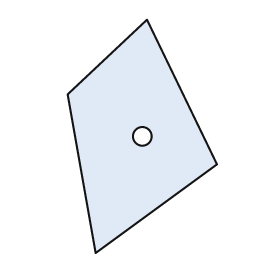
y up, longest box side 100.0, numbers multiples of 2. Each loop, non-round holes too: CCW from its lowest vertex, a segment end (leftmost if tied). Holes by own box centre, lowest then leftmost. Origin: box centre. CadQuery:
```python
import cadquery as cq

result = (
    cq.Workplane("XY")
    .moveTo(-20.0, -50.0)
    .lineTo(32.0, -12.0)
    .lineTo(2.0, 50.0)
    .lineTo(-32.0, 18.0)
    .close()
    .moveTo(0.0, 0.0)
    .circle(4.0)
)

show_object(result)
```